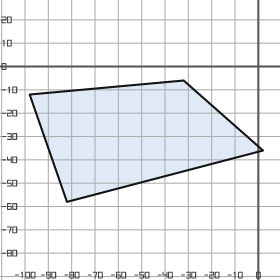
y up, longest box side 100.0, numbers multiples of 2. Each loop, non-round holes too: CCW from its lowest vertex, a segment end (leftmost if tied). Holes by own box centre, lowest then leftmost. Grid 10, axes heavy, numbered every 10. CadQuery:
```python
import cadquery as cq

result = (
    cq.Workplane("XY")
    .moveTo(-82.0, -58.0)
    .lineTo(2.0, -36.0)
    .lineTo(-32.0, -6.0)
    .lineTo(-98.0, -12.0)
    .close()
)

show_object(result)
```